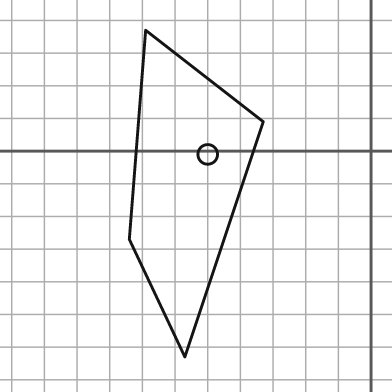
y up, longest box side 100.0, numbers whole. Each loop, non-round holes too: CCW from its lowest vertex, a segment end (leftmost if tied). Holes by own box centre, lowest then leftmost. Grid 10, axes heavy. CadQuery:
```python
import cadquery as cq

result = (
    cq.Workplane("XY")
    .moveTo(-57.0, -63.0)
    .lineTo(-33.0, 9.0)
    .lineTo(-69.0, 37.0)
    .lineTo(-74.0, -27.0)
    .close()
    .moveTo(-50.0, -1.0)
    .circle(3.0)
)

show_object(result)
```